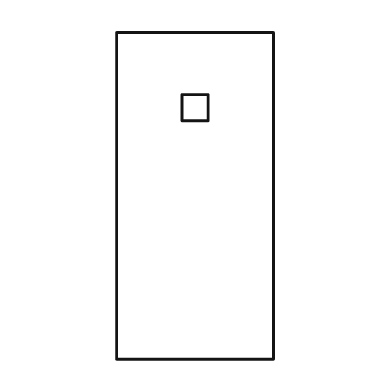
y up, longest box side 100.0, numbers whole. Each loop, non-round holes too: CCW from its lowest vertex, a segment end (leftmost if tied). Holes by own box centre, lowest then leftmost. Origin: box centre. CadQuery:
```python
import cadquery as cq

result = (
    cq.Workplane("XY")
    .moveTo(-24.0, -50.0)
    .lineTo(24.0, -50.0)
    .lineTo(24.0, 50.0)
    .lineTo(-24.0, 50.0)
    .close()
    .moveTo(-4.0, 23.0)
    .lineTo(4.0, 23.0)
    .lineTo(4.0, 31.0)
    .lineTo(-4.0, 31.0)
    .close()
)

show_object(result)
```